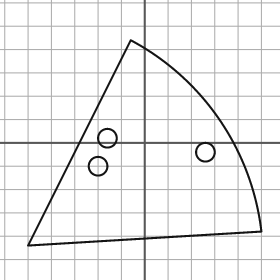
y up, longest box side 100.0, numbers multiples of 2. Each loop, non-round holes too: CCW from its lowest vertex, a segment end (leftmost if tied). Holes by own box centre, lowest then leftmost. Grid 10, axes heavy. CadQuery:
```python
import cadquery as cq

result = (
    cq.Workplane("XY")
    .moveTo(-50.0, -44.0)
    .lineTo(50.0, -38.0)
    .threePointArc((32.0, 10.0), (-6.0, 44.0))
    .close()
    .moveTo(-20.0, -10.0)
    .circle(4.0)
    .moveTo(26.0, -4.0)
    .circle(4.0)
    .moveTo(-16.0, 2.0)
    .circle(4.0)
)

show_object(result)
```